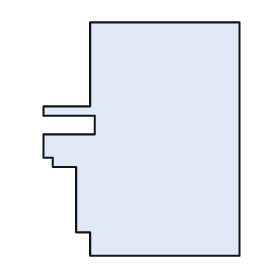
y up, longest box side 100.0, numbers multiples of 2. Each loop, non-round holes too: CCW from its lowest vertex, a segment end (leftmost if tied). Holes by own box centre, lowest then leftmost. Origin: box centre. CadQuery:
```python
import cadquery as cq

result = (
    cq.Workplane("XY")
    .moveTo(-22.0, -50.0)
    .lineTo(42.0, -50.0)
    .lineTo(42.0, 50.0)
    .lineTo(-22.0, 50.0)
    .lineTo(-22.0, 14.0)
    .lineTo(-42.0, 14.0)
    .lineTo(-42.0, 10.0)
    .lineTo(-20.0, 10.0)
    .lineTo(-20.0, 2.0)
    .lineTo(-42.0, 2.0)
    .lineTo(-42.0, -8.0)
    .lineTo(-38.0, -8.0)
    .lineTo(-38.0, -12.0)
    .lineTo(-28.0, -12.0)
    .lineTo(-28.0, -40.0)
    .lineTo(-22.0, -40.0)
    .close()
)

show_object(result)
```